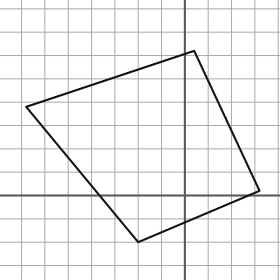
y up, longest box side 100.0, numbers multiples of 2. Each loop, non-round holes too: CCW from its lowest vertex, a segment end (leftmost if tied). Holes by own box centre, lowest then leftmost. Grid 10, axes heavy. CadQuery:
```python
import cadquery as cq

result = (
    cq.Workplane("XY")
    .moveTo(-20.0, -20.0)
    .lineTo(32.0, 2.0)
    .lineTo(4.0, 62.0)
    .lineTo(-68.0, 38.0)
    .close()
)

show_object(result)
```